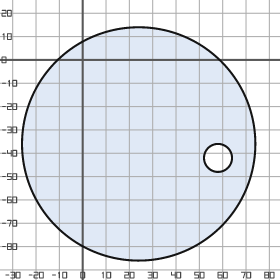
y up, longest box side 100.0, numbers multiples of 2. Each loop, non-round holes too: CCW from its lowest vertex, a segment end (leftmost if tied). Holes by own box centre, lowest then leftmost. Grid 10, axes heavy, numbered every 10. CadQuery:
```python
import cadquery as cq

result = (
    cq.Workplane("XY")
    .moveTo(24.0, -36.0)
    .circle(50.0)
    .moveTo(58.0, -42.0)
    .circle(6.0)
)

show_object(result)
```